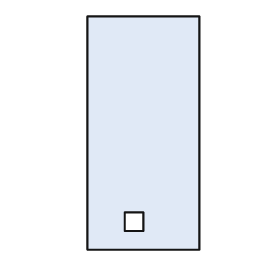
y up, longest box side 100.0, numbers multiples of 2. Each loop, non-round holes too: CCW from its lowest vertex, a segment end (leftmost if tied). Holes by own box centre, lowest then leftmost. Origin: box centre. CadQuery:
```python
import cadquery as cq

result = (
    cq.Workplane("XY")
    .moveTo(-24.0, -50.0)
    .lineTo(24.0, -50.0)
    .lineTo(24.0, 50.0)
    .lineTo(-24.0, 50.0)
    .close()
    .moveTo(-8.0, -42.0)
    .lineTo(0.0, -42.0)
    .lineTo(0.0, -34.0)
    .lineTo(-8.0, -34.0)
    .close()
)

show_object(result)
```